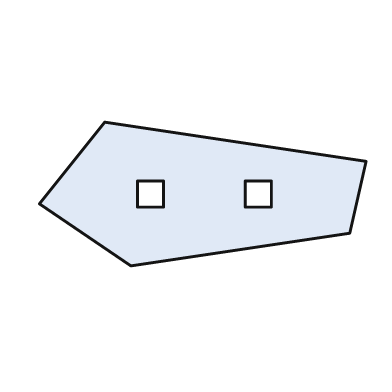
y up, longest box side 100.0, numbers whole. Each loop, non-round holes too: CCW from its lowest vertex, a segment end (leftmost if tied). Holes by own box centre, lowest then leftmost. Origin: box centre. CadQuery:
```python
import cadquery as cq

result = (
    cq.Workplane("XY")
    .moveTo(-22.0, -22.0)
    .lineTo(45.0, -12.0)
    .lineTo(50.0, 10.0)
    .lineTo(-30.0, 22.0)
    .lineTo(-50.0, -3.0)
    .close()
    .moveTo(-20.0, -4.0)
    .lineTo(-12.0, -4.0)
    .lineTo(-12.0, 4.0)
    .lineTo(-20.0, 4.0)
    .close()
    .moveTo(13.0, -4.0)
    .lineTo(21.0, -4.0)
    .lineTo(21.0, 4.0)
    .lineTo(13.0, 4.0)
    .close()
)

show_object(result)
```